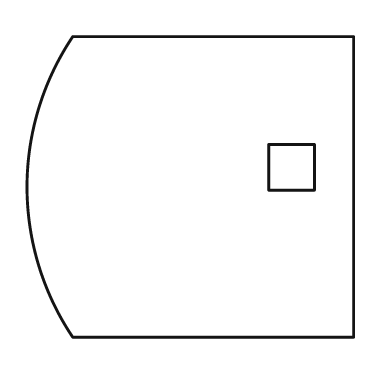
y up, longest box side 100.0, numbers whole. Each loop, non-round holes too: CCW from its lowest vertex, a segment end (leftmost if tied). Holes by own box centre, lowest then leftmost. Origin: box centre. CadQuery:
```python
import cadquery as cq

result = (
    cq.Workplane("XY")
    .moveTo(-36.0, -46.0)
    .lineTo(50.0, -46.0)
    .lineTo(50.0, 46.0)
    .lineTo(-36.0, 46.0)
    .threePointArc((-50.0, 0.0), (-36.0, -46.0))
    .close()
    .moveTo(24.0, -1.0)
    .lineTo(38.0, -1.0)
    .lineTo(38.0, 13.0)
    .lineTo(24.0, 13.0)
    .close()
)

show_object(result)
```